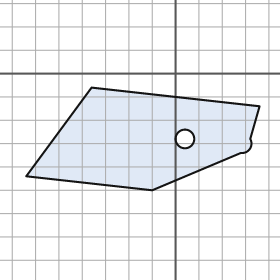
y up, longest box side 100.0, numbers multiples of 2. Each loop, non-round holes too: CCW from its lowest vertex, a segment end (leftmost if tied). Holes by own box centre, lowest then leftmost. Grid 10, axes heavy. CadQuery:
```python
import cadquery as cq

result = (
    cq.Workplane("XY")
    .moveTo(-10.0, -50.0)
    .lineTo(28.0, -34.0)
    .threePointArc((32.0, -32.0), (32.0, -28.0))
    .lineTo(36.0, -14.0)
    .lineTo(-36.0, -6.0)
    .lineTo(-64.0, -44.0)
    .close()
    .moveTo(4.0, -28.0)
    .circle(4.0)
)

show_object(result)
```